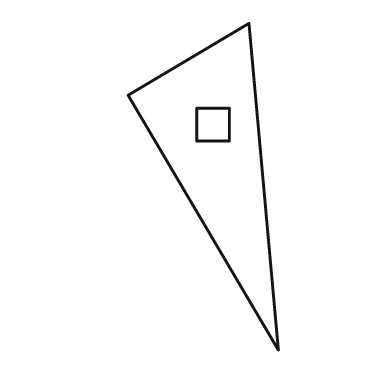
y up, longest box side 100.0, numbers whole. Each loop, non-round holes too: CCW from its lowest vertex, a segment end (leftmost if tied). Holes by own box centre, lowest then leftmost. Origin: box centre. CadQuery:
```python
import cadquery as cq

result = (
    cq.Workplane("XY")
    .moveTo(23.0, -50.0)
    .lineTo(14.0, 50.0)
    .lineTo(-23.0, 28.0)
    .close()
    .moveTo(-2.0, 14.0)
    .lineTo(8.0, 14.0)
    .lineTo(8.0, 24.0)
    .lineTo(-2.0, 24.0)
    .close()
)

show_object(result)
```